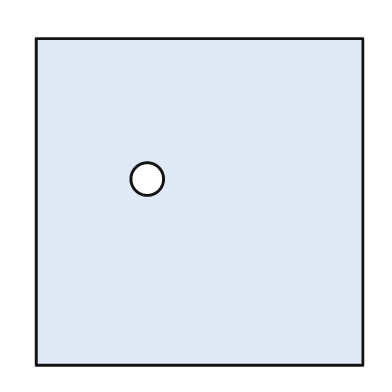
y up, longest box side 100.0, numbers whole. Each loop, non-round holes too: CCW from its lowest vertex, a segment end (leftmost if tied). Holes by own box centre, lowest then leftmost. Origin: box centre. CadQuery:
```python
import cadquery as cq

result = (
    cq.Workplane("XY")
    .moveTo(-50.0, -50.0)
    .lineTo(50.0, -50.0)
    .lineTo(50.0, 50.0)
    .lineTo(-50.0, 50.0)
    .close()
    .moveTo(-16.0, 7.0)
    .circle(5.0)
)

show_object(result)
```